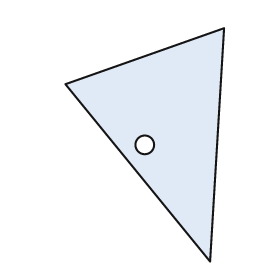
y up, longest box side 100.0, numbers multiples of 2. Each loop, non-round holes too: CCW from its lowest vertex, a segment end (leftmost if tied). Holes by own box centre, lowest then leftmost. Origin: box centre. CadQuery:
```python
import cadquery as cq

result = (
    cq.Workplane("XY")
    .moveTo(28.0, -50.0)
    .lineTo(34.0, 50.0)
    .lineTo(-34.0, 26.0)
    .close()
    .moveTo(0.0, 0.0)
    .circle(4.0)
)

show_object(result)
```